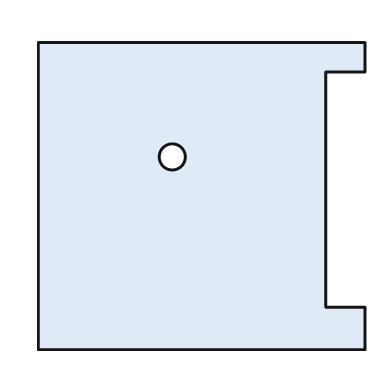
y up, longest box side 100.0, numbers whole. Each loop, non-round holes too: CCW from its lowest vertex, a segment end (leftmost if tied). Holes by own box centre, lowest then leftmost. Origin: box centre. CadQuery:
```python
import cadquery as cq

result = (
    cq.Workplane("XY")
    .moveTo(-50.0, -47.0)
    .lineTo(50.0, -47.0)
    .lineTo(50.0, -34.0)
    .lineTo(38.0, -34.0)
    .lineTo(38.0, 38.0)
    .lineTo(50.0, 38.0)
    .lineTo(50.0, 47.0)
    .lineTo(-50.0, 47.0)
    .close()
    .moveTo(-9.0, 12.0)
    .circle(4.0)
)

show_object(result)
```